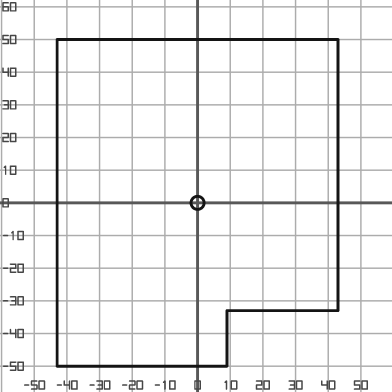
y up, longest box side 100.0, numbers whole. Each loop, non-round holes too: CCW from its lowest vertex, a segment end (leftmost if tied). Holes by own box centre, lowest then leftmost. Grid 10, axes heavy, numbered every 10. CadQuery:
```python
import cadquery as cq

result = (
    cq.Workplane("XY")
    .moveTo(-43.0, -50.0)
    .lineTo(9.0, -50.0)
    .lineTo(9.0, -33.0)
    .lineTo(43.0, -33.0)
    .lineTo(43.0, 50.0)
    .lineTo(-43.0, 50.0)
    .close()
    .moveTo(0.0, 0.0)
    .circle(2.0)
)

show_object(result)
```